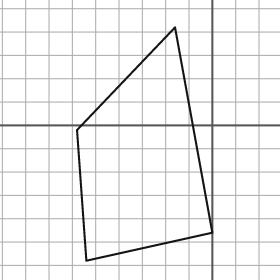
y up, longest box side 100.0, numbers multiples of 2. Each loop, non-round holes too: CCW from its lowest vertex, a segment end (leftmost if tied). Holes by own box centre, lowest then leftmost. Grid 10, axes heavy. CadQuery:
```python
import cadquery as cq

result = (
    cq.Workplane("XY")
    .moveTo(-54.0, -58.0)
    .lineTo(0.0, -46.0)
    .lineTo(-16.0, 42.0)
    .lineTo(-58.0, -2.0)
    .close()
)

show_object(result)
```